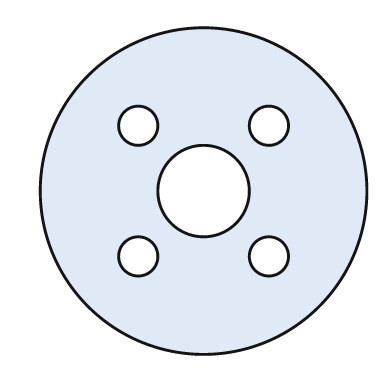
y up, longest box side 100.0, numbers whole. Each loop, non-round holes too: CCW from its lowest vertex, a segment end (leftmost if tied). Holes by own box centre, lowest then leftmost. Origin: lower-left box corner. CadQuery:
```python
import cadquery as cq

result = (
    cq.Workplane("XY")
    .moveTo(50.0, 50.0)
    .circle(50.0)
    .moveTo(30.0, 30.0)
    .circle(6.0)
    .moveTo(70.0, 30.0)
    .circle(6.0)
    .moveTo(50.0, 50.0)
    .circle(14.0)
    .moveTo(30.0, 70.0)
    .circle(6.0)
    .moveTo(70.0, 70.0)
    .circle(6.0)
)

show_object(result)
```